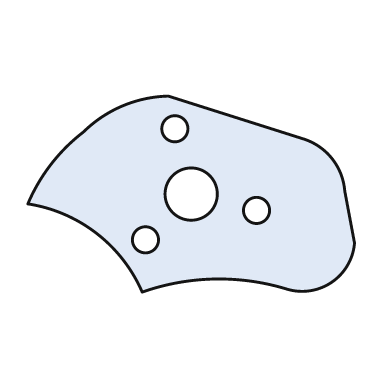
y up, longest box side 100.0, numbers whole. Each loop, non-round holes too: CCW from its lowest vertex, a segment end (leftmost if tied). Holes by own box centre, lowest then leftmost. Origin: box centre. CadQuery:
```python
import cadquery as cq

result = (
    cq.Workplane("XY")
    .moveTo(-15.0, -30.0)
    .threePointArc((7.0, -26.0), (29.0, -29.0))
    .threePointArc((43.0, -27.0), (50.0, -15.0))
    .lineTo(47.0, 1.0)
    .threePointArc((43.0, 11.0), (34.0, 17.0))
    .lineTo(-7.0, 30.0)
    .threePointArc((-21.0, 27.0), (-33.0, 19.0))
    .threePointArc((-43.0, 9.0), (-50.0, -3.0))
    .threePointArc((-29.0, -12.0), (-15.0, -30.0))
    .close()
    .moveTo(-14.0, -14.0)
    .circle(4.0)
    .moveTo(20.0, -5.0)
    .circle(4.0)
    .moveTo(0.0, 0.0)
    .circle(8.0)
    .moveTo(-5.0, 20.0)
    .circle(4.0)
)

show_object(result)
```